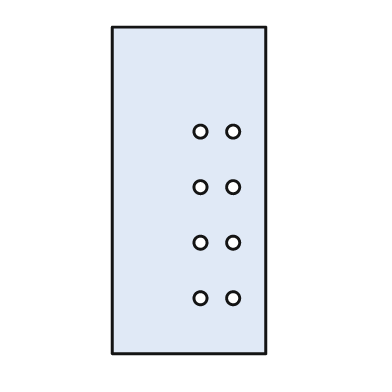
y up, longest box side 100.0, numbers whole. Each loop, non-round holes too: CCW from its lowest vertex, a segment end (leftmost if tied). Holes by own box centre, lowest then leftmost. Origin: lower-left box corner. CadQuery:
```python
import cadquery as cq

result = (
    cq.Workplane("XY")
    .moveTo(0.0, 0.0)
    .lineTo(47.0, 0.0)
    .lineTo(47.0, 100.0)
    .lineTo(0.0, 100.0)
    .close()
    .moveTo(27.0, 17.0)
    .circle(2.0)
    .moveTo(37.0, 17.0)
    .circle(2.0)
    .moveTo(27.0, 34.0)
    .circle(2.0)
    .moveTo(37.0, 34.0)
    .circle(2.0)
    .moveTo(27.0, 51.0)
    .circle(2.0)
    .moveTo(37.0, 51.0)
    .circle(2.0)
    .moveTo(27.0, 68.0)
    .circle(2.0)
    .moveTo(37.0, 68.0)
    .circle(2.0)
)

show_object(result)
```